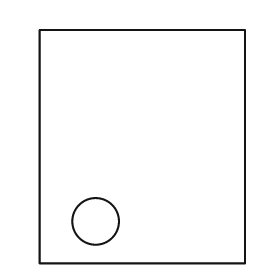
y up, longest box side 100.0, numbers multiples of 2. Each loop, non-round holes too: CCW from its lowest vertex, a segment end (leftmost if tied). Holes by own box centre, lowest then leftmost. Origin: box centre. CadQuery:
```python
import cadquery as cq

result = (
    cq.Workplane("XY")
    .moveTo(-44.0, -50.0)
    .lineTo(44.0, -50.0)
    .lineTo(44.0, 50.0)
    .lineTo(-44.0, 50.0)
    .close()
    .moveTo(-20.0, -32.0)
    .circle(10.0)
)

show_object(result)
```